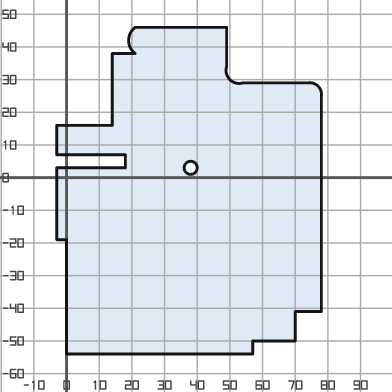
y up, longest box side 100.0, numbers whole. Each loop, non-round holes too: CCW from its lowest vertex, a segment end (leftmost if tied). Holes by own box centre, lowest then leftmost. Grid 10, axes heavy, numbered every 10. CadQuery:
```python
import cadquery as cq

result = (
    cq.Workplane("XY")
    .moveTo(0.0, -54.0)
    .lineTo(57.0, -54.0)
    .lineTo(57.0, -50.0)
    .lineTo(70.0, -50.0)
    .lineTo(70.0, -41.0)
    .lineTo(78.0, -41.0)
    .lineTo(78.0, 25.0)
    .threePointArc((77.0, 28.0), (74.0, 29.0))
    .lineTo(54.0, 29.0)
    .threePointArc((50.0, 30.0), (49.0, 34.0))
    .lineTo(49.0, 46.0)
    .lineTo(21.0, 46.0)
    .threePointArc((19.0, 42.0), (21.0, 38.0))
    .lineTo(14.0, 38.0)
    .lineTo(14.0, 16.0)
    .lineTo(-3.0, 16.0)
    .lineTo(-3.0, 7.0)
    .lineTo(18.0, 7.0)
    .lineTo(18.0, 3.0)
    .lineTo(-3.0, 3.0)
    .lineTo(-3.0, -19.0)
    .lineTo(0.0, -19.0)
    .close()
    .moveTo(38.0, 3.0)
    .circle(2.0)
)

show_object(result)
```